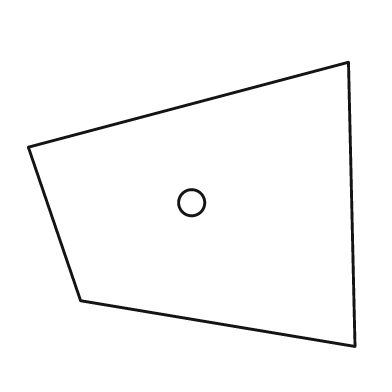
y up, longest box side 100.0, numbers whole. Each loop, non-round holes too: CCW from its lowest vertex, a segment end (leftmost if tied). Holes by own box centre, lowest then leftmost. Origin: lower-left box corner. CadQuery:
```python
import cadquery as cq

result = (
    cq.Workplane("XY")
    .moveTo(100.0, 0.0)
    .lineTo(98.0, 87.0)
    .lineTo(0.0, 61.0)
    .lineTo(16.0, 14.0)
    .close()
    .moveTo(50.0, 44.0)
    .circle(4.0)
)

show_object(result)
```